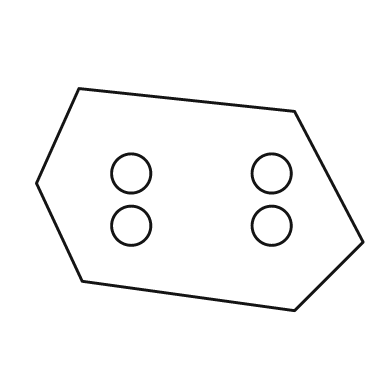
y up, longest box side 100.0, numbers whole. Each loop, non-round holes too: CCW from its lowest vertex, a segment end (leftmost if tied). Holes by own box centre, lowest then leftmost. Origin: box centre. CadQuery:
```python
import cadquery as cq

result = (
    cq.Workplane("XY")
    .moveTo(29.0, -34.0)
    .lineTo(50.0, -13.0)
    .lineTo(29.0, 27.0)
    .lineTo(-37.0, 34.0)
    .lineTo(-50.0, 5.0)
    .lineTo(-36.0, -25.0)
    .close()
    .moveTo(-21.0, -8.0)
    .circle(6.0)
    .moveTo(22.0, -8.0)
    .circle(6.0)
    .moveTo(-21.0, 8.0)
    .circle(6.0)
    .moveTo(22.0, 8.0)
    .circle(6.0)
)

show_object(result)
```